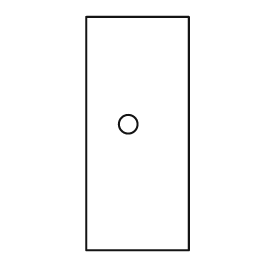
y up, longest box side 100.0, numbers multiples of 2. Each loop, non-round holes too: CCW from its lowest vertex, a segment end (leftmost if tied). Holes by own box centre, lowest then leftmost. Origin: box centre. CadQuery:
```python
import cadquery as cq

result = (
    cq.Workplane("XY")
    .moveTo(-22.0, -50.0)
    .lineTo(22.0, -50.0)
    .lineTo(22.0, 50.0)
    .lineTo(-22.0, 50.0)
    .close()
    .moveTo(-4.0, 4.0)
    .circle(4.0)
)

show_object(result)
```